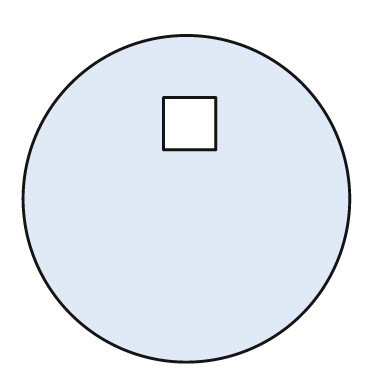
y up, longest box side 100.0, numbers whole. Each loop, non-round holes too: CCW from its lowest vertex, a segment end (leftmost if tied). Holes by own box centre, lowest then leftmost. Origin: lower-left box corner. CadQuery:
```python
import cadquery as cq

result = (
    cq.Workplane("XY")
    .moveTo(50.0, 50.0)
    .circle(50.0)
    .moveTo(43.0, 65.0)
    .lineTo(59.0, 65.0)
    .lineTo(59.0, 81.0)
    .lineTo(43.0, 81.0)
    .close()
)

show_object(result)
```